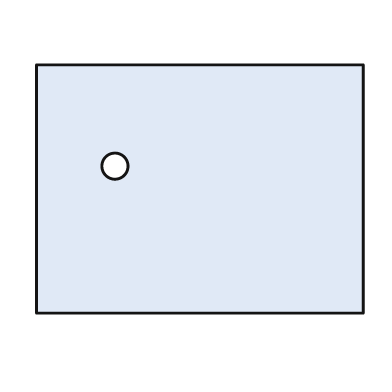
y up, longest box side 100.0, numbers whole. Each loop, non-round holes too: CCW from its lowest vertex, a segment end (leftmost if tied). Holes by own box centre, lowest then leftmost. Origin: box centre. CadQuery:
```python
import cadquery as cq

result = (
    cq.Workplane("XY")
    .moveTo(-50.0, -38.0)
    .lineTo(50.0, -38.0)
    .lineTo(50.0, 38.0)
    .lineTo(-50.0, 38.0)
    .close()
    .moveTo(-26.0, 7.0)
    .circle(4.0)
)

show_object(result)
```